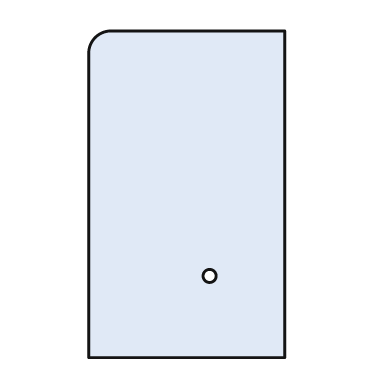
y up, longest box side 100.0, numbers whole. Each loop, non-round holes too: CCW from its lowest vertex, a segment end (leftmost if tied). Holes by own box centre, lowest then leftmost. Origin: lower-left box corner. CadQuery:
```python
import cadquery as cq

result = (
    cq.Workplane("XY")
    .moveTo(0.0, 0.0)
    .lineTo(60.0, 0.0)
    .lineTo(60.0, 100.0)
    .lineTo(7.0, 100.0)
    .threePointArc((2.0, 98.0), (0.0, 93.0))
    .close()
    .moveTo(37.0, 25.0)
    .circle(2.0)
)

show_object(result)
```